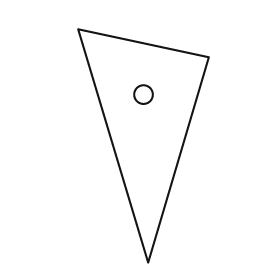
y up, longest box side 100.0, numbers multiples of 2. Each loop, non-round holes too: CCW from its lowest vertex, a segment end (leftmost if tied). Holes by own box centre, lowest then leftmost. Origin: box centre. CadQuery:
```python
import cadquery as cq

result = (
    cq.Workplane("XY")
    .moveTo(2.0, -50.0)
    .lineTo(28.0, 38.0)
    .lineTo(-28.0, 50.0)
    .close()
    .moveTo(0.0, 22.0)
    .circle(4.0)
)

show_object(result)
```